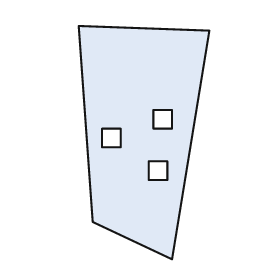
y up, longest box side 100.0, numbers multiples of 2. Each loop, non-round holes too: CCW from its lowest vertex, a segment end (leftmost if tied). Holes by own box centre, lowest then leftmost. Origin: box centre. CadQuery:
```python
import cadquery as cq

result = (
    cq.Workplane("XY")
    .moveTo(12.0, -50.0)
    .lineTo(28.0, 48.0)
    .lineTo(-28.0, 50.0)
    .lineTo(-22.0, -34.0)
    .close()
    .moveTo(2.0, -16.0)
    .lineTo(10.0, -16.0)
    .lineTo(10.0, -8.0)
    .lineTo(2.0, -8.0)
    .close()
    .moveTo(-18.0, -2.0)
    .lineTo(-10.0, -2.0)
    .lineTo(-10.0, 6.0)
    .lineTo(-18.0, 6.0)
    .close()
    .moveTo(4.0, 6.0)
    .lineTo(12.0, 6.0)
    .lineTo(12.0, 14.0)
    .lineTo(4.0, 14.0)
    .close()
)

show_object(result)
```